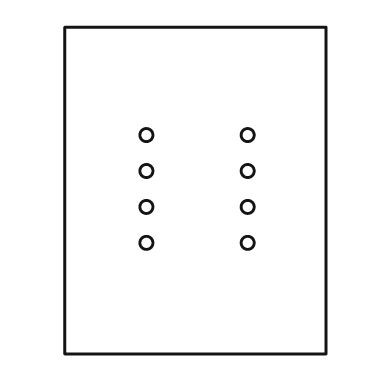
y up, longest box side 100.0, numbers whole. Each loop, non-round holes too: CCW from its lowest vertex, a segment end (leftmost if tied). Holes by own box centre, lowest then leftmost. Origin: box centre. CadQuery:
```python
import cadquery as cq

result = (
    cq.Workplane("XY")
    .moveTo(-40.0, -50.0)
    .lineTo(40.0, -50.0)
    .lineTo(40.0, 50.0)
    .lineTo(-40.0, 50.0)
    .close()
    .moveTo(-15.0, -16.0)
    .circle(2.0)
    .moveTo(16.0, -16.0)
    .circle(2.0)
    .moveTo(-15.0, -5.0)
    .circle(2.0)
    .moveTo(16.0, -5.0)
    .circle(2.0)
    .moveTo(-15.0, 6.0)
    .circle(2.0)
    .moveTo(16.0, 6.0)
    .circle(2.0)
    .moveTo(-15.0, 17.0)
    .circle(2.0)
    .moveTo(16.0, 17.0)
    .circle(2.0)
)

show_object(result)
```